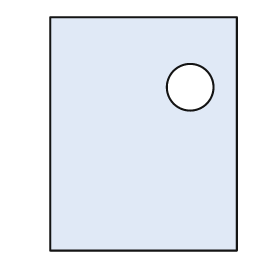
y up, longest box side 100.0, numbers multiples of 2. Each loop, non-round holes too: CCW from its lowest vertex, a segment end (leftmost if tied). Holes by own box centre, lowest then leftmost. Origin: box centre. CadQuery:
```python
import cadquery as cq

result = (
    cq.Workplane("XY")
    .moveTo(-40.0, -50.0)
    .lineTo(40.0, -50.0)
    .lineTo(40.0, 50.0)
    .lineTo(-40.0, 50.0)
    .close()
    .moveTo(20.0, 20.0)
    .circle(10.0)
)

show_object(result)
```